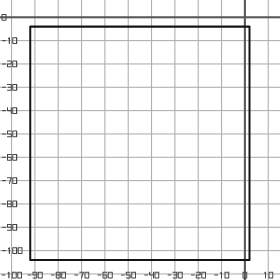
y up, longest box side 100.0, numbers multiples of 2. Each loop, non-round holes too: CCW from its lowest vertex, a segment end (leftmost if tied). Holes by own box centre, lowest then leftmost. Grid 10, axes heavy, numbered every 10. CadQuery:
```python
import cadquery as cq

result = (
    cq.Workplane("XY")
    .moveTo(-92.0, -104.0)
    .lineTo(2.0, -104.0)
    .lineTo(2.0, -4.0)
    .lineTo(-92.0, -4.0)
    .close()
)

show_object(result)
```